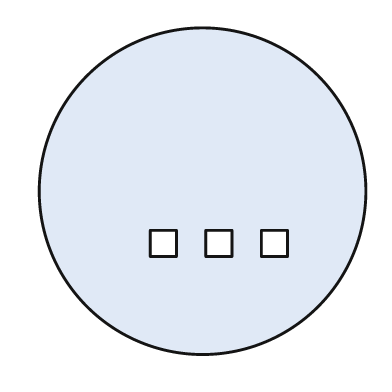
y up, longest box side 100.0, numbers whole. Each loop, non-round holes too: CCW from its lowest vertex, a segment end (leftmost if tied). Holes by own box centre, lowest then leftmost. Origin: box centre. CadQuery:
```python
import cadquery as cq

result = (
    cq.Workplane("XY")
    .moveTo(0.0, 0.0)
    .circle(50.0)
    .moveTo(-16.0, -20.0)
    .lineTo(-8.0, -20.0)
    .lineTo(-8.0, -12.0)
    .lineTo(-16.0, -12.0)
    .close()
    .moveTo(1.0, -20.0)
    .lineTo(9.0, -20.0)
    .lineTo(9.0, -12.0)
    .lineTo(1.0, -12.0)
    .close()
    .moveTo(18.0, -20.0)
    .lineTo(26.0, -20.0)
    .lineTo(26.0, -12.0)
    .lineTo(18.0, -12.0)
    .close()
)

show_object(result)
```